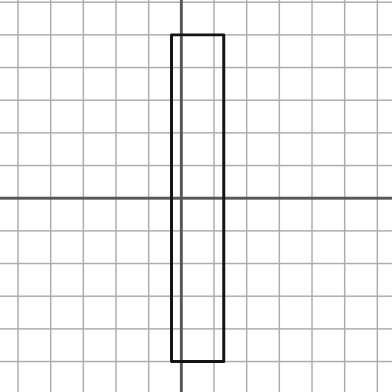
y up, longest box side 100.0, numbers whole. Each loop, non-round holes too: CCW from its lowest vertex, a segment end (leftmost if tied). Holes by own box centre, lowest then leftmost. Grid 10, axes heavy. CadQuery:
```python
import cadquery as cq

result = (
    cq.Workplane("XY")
    .moveTo(-3.0, -50.0)
    .lineTo(13.0, -50.0)
    .lineTo(13.0, 50.0)
    .lineTo(-3.0, 50.0)
    .close()
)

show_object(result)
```